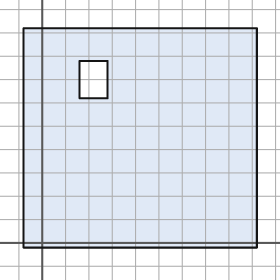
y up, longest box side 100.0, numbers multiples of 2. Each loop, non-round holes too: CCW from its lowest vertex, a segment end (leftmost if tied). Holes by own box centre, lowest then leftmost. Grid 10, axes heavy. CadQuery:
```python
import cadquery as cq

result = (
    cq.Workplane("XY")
    .moveTo(-8.0, -2.0)
    .lineTo(92.0, -2.0)
    .lineTo(92.0, 92.0)
    .lineTo(-8.0, 92.0)
    .close()
    .moveTo(16.0, 62.0)
    .lineTo(28.0, 62.0)
    .lineTo(28.0, 78.0)
    .lineTo(16.0, 78.0)
    .close()
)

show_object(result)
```